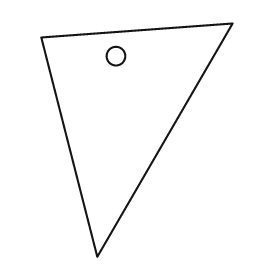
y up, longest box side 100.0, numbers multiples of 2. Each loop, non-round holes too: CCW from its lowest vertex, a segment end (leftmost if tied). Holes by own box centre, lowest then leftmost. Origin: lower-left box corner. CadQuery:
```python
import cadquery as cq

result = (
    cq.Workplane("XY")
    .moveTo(24.0, 0.0)
    .lineTo(82.0, 100.0)
    .lineTo(0.0, 94.0)
    .close()
    .moveTo(32.0, 86.0)
    .circle(4.0)
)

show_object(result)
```